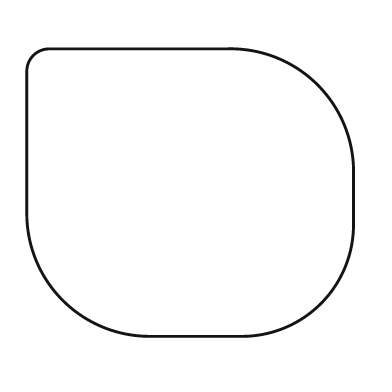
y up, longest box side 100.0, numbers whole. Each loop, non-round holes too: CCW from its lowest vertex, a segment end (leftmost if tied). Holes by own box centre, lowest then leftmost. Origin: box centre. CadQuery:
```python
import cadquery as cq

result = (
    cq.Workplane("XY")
    .moveTo(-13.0, -44.0)
    .lineTo(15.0, -44.0)
    .threePointArc((40.0, -34.0), (50.0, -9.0))
    .lineTo(50.0, 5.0)
    .threePointArc((39.0, 33.0), (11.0, 44.0))
    .lineTo(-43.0, 44.0)
    .threePointArc((-48.0, 42.0), (-50.0, 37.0))
    .lineTo(-50.0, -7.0)
    .threePointArc((-39.0, -33.0), (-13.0, -44.0))
    .close()
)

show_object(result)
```